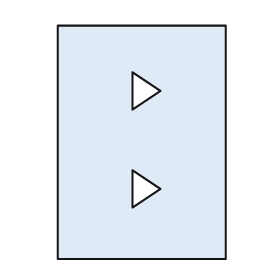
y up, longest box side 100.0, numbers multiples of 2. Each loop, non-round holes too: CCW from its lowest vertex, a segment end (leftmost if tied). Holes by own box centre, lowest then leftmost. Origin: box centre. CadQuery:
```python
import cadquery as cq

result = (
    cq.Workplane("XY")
    .moveTo(-36.0, -50.0)
    .lineTo(36.0, -50.0)
    .lineTo(36.0, 50.0)
    .lineTo(-36.0, 50.0)
    .close()
    .moveTo(-4.0, -28.0)
    .lineTo(8.0, -20.0)
    .lineTo(-4.0, -12.0)
    .close()
    .moveTo(-4.0, 14.0)
    .lineTo(8.0, 22.0)
    .lineTo(-4.0, 30.0)
    .close()
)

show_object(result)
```